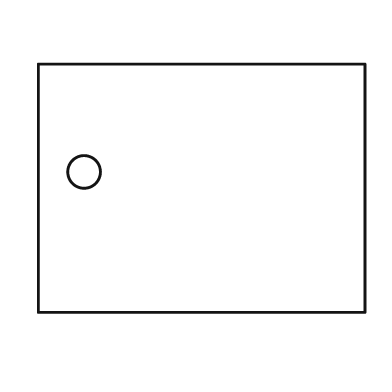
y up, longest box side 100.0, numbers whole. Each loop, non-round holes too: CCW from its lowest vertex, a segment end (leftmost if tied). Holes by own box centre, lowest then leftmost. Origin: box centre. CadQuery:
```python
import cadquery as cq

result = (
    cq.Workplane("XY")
    .moveTo(-50.0, -38.0)
    .lineTo(50.0, -38.0)
    .lineTo(50.0, 38.0)
    .lineTo(-50.0, 38.0)
    .close()
    .moveTo(-36.0, 5.0)
    .circle(5.0)
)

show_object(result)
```